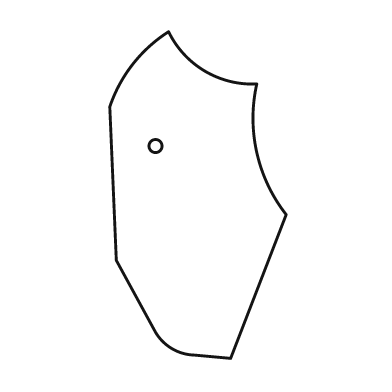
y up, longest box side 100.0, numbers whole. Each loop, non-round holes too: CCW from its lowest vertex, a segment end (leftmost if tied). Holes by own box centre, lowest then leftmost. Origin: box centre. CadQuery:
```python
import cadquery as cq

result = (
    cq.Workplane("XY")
    .moveTo(10.0, -50.0)
    .lineTo(27.0, -6.0)
    .threePointArc((18.0, 13.0), (18.0, 34.0))
    .threePointArc((2.0, 38.0), (-9.0, 50.0))
    .threePointArc((-20.0, 40.0), (-27.0, 27.0))
    .lineTo(-25.0, -20.0)
    .lineTo(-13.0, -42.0)
    .threePointArc((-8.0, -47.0), (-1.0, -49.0))
    .close()
    .moveTo(-13.0, 15.0)
    .circle(2.0)
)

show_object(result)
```